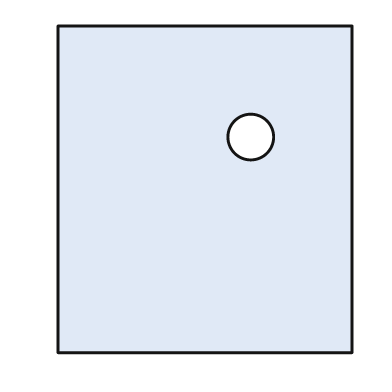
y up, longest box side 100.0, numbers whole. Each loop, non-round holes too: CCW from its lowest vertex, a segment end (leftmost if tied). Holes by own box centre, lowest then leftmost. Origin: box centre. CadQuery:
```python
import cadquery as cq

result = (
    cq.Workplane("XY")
    .moveTo(-45.0, -50.0)
    .lineTo(45.0, -50.0)
    .lineTo(45.0, 50.0)
    .lineTo(-45.0, 50.0)
    .close()
    .moveTo(14.0, 16.0)
    .circle(7.0)
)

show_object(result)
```